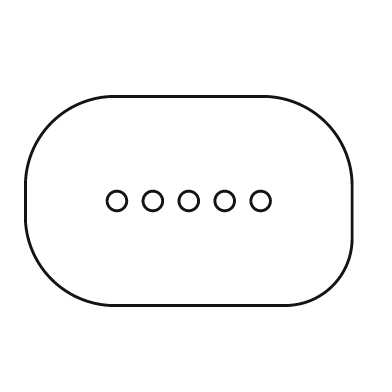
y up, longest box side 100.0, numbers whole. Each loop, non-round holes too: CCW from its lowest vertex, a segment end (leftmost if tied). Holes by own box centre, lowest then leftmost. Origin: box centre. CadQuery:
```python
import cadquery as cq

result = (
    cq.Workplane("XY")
    .moveTo(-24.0, -32.0)
    .lineTo(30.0, -32.0)
    .threePointArc((44.0, -26.0), (50.0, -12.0))
    .lineTo(50.0, 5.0)
    .threePointArc((42.0, 24.0), (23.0, 32.0))
    .lineTo(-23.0, 32.0)
    .threePointArc((-42.0, 24.0), (-50.0, 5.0))
    .lineTo(-50.0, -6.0)
    .threePointArc((-42.0, -24.0), (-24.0, -32.0))
    .close()
    .moveTo(-22.0, 0.0)
    .circle(3.0)
    .moveTo(-11.0, 0.0)
    .circle(3.0)
    .moveTo(0.0, 0.0)
    .circle(3.0)
    .moveTo(11.0, 0.0)
    .circle(3.0)
    .moveTo(22.0, 0.0)
    .circle(3.0)
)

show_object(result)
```